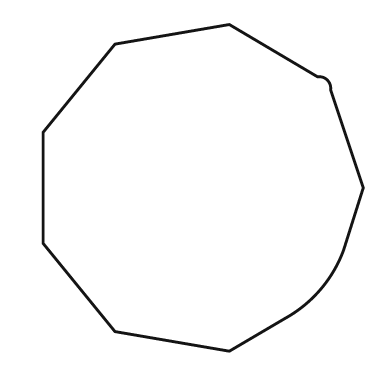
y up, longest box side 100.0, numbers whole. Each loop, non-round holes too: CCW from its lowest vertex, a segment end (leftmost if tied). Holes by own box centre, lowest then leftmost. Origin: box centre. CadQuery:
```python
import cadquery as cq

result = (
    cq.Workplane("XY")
    .moveTo(8.0, -50.0)
    .lineTo(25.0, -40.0)
    .threePointArc((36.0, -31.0), (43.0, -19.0))
    .lineTo(49.0, 0.0)
    .lineTo(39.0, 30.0)
    .threePointArc((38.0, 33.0), (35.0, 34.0))
    .lineTo(8.0, 50.0)
    .lineTo(-27.0, 44.0)
    .lineTo(-49.0, 17.0)
    .lineTo(-49.0, -17.0)
    .lineTo(-27.0, -44.0)
    .close()
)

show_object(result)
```